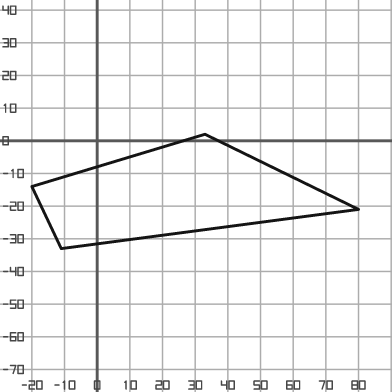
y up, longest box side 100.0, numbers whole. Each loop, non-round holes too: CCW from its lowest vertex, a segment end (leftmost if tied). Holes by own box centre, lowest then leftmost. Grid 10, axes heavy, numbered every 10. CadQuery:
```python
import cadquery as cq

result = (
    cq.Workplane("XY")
    .moveTo(-11.0, -33.0)
    .lineTo(80.0, -21.0)
    .lineTo(33.0, 2.0)
    .lineTo(-20.0, -14.0)
    .close()
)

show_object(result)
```